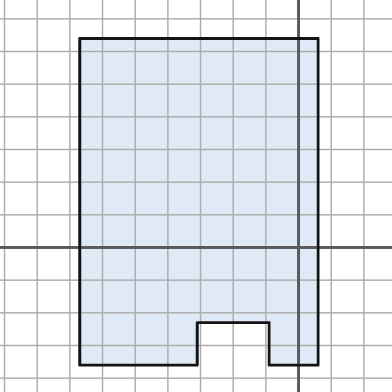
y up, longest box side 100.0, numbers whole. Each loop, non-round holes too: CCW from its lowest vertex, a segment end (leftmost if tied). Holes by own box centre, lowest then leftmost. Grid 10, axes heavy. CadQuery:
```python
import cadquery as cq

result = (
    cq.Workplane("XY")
    .moveTo(-67.0, -36.0)
    .lineTo(-31.0, -36.0)
    .lineTo(-31.0, -23.0)
    .lineTo(-9.0, -23.0)
    .lineTo(-9.0, -36.0)
    .lineTo(6.0, -36.0)
    .lineTo(6.0, 64.0)
    .lineTo(-67.0, 64.0)
    .close()
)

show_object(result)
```